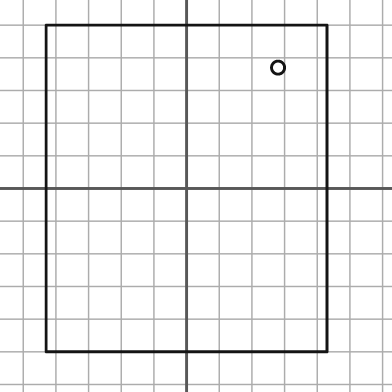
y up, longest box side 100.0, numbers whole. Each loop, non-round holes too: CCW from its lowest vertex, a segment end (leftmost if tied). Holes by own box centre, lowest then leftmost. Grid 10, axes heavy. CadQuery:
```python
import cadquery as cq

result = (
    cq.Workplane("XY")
    .moveTo(-43.0, -50.0)
    .lineTo(43.0, -50.0)
    .lineTo(43.0, 50.0)
    .lineTo(-43.0, 50.0)
    .close()
    .moveTo(28.0, 37.0)
    .circle(2.0)
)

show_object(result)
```